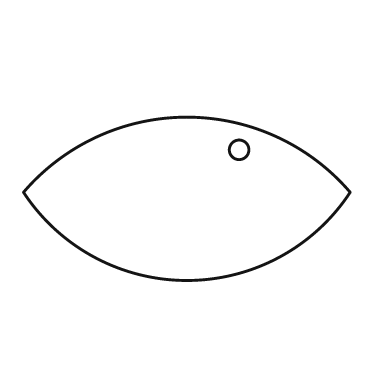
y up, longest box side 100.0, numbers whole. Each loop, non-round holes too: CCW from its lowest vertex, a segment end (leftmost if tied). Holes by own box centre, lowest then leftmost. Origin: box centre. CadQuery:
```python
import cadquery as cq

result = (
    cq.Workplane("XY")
    .moveTo(-50.0, 2.0)
    .threePointArc((0.0, -25.0), (50.0, 2.0))
    .threePointArc((0.0, 25.0), (-50.0, 2.0))
    .close()
    .moveTo(16.0, 15.0)
    .circle(3.0)
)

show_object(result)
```